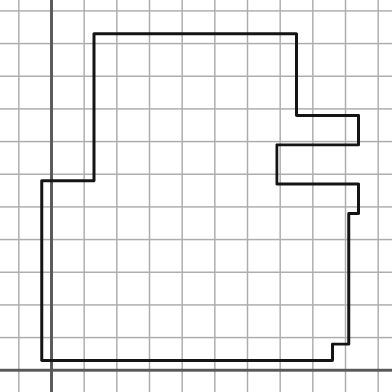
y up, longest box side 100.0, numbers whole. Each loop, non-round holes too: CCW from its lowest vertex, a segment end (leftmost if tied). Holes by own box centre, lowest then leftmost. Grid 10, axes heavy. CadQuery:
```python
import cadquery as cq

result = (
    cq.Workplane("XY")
    .moveTo(-3.0, 3.0)
    .lineTo(86.0, 3.0)
    .lineTo(86.0, 8.0)
    .lineTo(91.0, 8.0)
    .lineTo(91.0, 48.0)
    .lineTo(94.0, 48.0)
    .lineTo(94.0, 57.0)
    .lineTo(69.0, 57.0)
    .lineTo(69.0, 69.0)
    .lineTo(94.0, 69.0)
    .lineTo(94.0, 78.0)
    .lineTo(75.0, 78.0)
    .lineTo(75.0, 103.0)
    .lineTo(13.0, 103.0)
    .lineTo(13.0, 58.0)
    .lineTo(-3.0, 58.0)
    .close()
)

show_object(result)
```